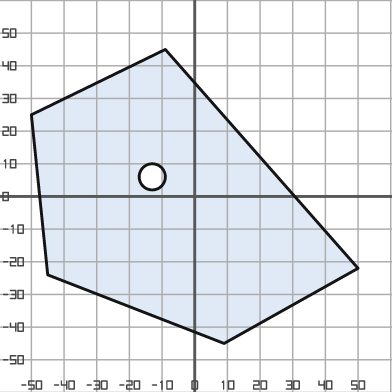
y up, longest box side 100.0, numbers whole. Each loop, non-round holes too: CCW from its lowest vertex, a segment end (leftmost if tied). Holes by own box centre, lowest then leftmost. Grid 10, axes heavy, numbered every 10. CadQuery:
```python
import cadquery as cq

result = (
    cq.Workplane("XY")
    .moveTo(9.0, -45.0)
    .lineTo(50.0, -22.0)
    .lineTo(-9.0, 45.0)
    .lineTo(-50.0, 25.0)
    .lineTo(-45.0, -24.0)
    .close()
    .moveTo(-13.0, 6.0)
    .circle(4.0)
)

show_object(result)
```